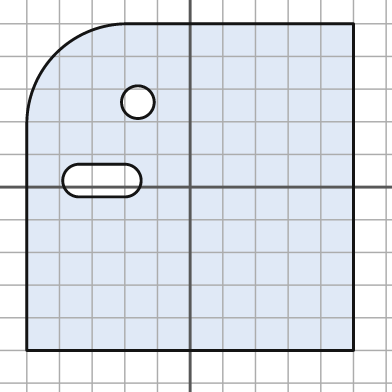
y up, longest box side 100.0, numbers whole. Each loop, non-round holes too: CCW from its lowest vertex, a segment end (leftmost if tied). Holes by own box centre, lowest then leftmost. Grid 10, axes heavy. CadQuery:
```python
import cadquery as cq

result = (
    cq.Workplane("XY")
    .moveTo(-50.0, -50.0)
    .lineTo(50.0, -50.0)
    .lineTo(50.0, 50.0)
    .lineTo(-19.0, 50.0)
    .threePointArc((-41.0, 41.0), (-50.0, 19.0))
    .close()
    .moveTo(-34.0, -3.0)
    .lineTo(-20.0, -3.0)
    .threePointArc((-15.0, 2.0), (-20.0, 7.0))
    .lineTo(-34.0, 7.0)
    .threePointArc((-39.0, 2.0), (-34.0, -3.0))
    .close()
    .moveTo(-16.0, 26.0)
    .circle(5.0)
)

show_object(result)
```